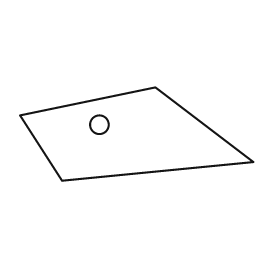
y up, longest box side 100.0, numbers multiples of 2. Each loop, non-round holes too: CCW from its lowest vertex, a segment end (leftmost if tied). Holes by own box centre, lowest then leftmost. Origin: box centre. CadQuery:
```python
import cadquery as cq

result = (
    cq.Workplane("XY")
    .moveTo(-32.0, -20.0)
    .lineTo(50.0, -12.0)
    .lineTo(8.0, 20.0)
    .lineTo(-50.0, 8.0)
    .close()
    .moveTo(-16.0, 4.0)
    .circle(4.0)
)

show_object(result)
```